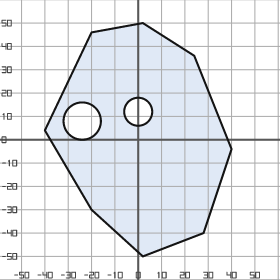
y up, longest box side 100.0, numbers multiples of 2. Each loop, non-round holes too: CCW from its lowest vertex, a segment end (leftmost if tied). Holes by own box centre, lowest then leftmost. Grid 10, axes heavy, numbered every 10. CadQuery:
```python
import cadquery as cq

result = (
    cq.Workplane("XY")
    .moveTo(2.0, -50.0)
    .lineTo(28.0, -40.0)
    .lineTo(40.0, -4.0)
    .lineTo(24.0, 36.0)
    .lineTo(2.0, 50.0)
    .lineTo(-20.0, 46.0)
    .lineTo(-40.0, 4.0)
    .lineTo(-20.0, -30.0)
    .close()
    .moveTo(-24.0, 8.0)
    .circle(8.0)
    .moveTo(0.0, 12.0)
    .circle(6.0)
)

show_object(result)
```